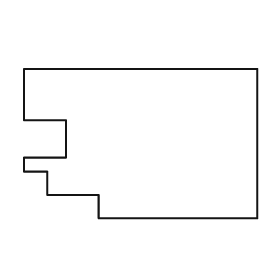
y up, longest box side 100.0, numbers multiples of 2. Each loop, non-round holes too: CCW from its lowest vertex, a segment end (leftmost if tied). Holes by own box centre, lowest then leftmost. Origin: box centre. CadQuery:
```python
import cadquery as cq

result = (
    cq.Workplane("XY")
    .moveTo(-18.0, -32.0)
    .lineTo(50.0, -32.0)
    .lineTo(50.0, 32.0)
    .lineTo(-50.0, 32.0)
    .lineTo(-50.0, 10.0)
    .lineTo(-32.0, 10.0)
    .lineTo(-32.0, -6.0)
    .lineTo(-50.0, -6.0)
    .lineTo(-50.0, -12.0)
    .lineTo(-40.0, -12.0)
    .lineTo(-40.0, -22.0)
    .lineTo(-18.0, -22.0)
    .close()
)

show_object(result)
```